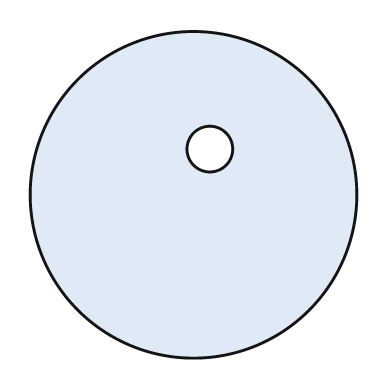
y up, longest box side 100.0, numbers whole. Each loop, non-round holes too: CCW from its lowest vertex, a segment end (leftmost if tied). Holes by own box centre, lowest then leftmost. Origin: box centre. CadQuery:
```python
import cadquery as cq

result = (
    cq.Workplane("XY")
    .moveTo(0.0, 0.0)
    .circle(50.0)
    .moveTo(5.0, 14.0)
    .circle(7.0)
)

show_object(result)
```